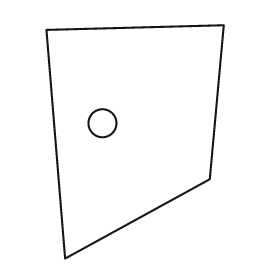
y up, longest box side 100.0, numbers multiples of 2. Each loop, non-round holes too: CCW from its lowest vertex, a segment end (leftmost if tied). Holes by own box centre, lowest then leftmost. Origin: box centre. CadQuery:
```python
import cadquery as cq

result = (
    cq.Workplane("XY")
    .moveTo(-30.0, -50.0)
    .lineTo(32.0, -16.0)
    .lineTo(38.0, 50.0)
    .lineTo(-38.0, 48.0)
    .close()
    .moveTo(-14.0, 8.0)
    .circle(6.0)
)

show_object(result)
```